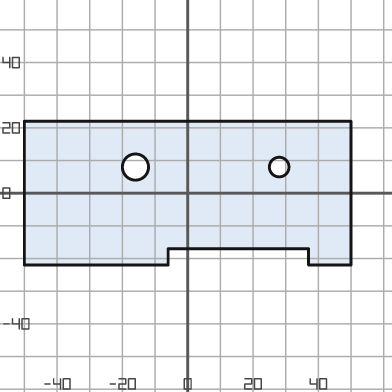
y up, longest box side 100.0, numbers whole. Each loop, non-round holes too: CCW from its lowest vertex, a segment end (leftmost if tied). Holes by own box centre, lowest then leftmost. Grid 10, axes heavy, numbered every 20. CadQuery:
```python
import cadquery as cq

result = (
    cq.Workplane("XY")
    .moveTo(-50.0, -22.0)
    .lineTo(-6.0, -22.0)
    .lineTo(-6.0, -17.0)
    .lineTo(37.0, -17.0)
    .lineTo(37.0, -22.0)
    .lineTo(50.0, -22.0)
    .lineTo(50.0, 22.0)
    .lineTo(-50.0, 22.0)
    .close()
    .moveTo(-16.0, 8.0)
    .circle(4.0)
    .moveTo(28.0, 8.0)
    .circle(3.0)
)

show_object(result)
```